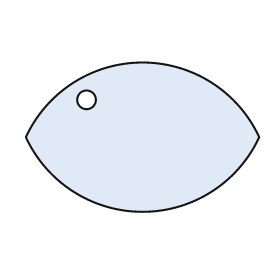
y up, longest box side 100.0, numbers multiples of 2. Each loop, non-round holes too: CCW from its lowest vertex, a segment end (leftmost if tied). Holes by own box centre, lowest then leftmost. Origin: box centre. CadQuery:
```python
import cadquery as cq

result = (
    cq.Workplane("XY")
    .moveTo(-50.0, 0.0)
    .threePointArc((0.0, -32.0), (50.0, 0.0))
    .threePointArc((0.0, 32.0), (-50.0, 0.0))
    .close()
    .moveTo(-24.0, 16.0)
    .circle(4.0)
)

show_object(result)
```